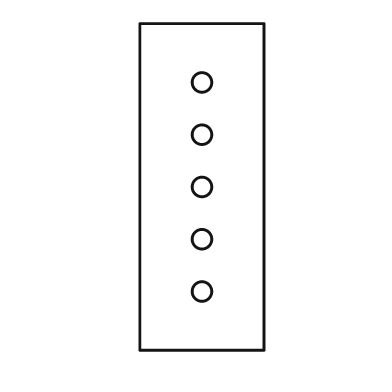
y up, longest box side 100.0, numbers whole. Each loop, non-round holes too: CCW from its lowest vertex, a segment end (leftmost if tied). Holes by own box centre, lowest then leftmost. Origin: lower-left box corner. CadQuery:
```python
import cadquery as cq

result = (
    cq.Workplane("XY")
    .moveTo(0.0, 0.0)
    .lineTo(38.0, 0.0)
    .lineTo(38.0, 100.0)
    .lineTo(0.0, 100.0)
    .close()
    .moveTo(19.0, 18.0)
    .circle(3.0)
    .moveTo(19.0, 34.0)
    .circle(3.0)
    .moveTo(19.0, 50.0)
    .circle(3.0)
    .moveTo(19.0, 66.0)
    .circle(3.0)
    .moveTo(19.0, 82.0)
    .circle(3.0)
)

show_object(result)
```